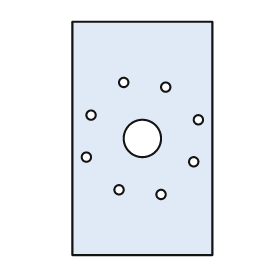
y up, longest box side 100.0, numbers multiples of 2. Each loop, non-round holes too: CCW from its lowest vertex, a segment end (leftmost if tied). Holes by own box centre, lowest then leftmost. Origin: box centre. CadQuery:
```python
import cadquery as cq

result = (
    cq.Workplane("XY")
    .moveTo(-30.0, -50.0)
    .lineTo(30.0, -50.0)
    .lineTo(30.0, 50.0)
    .lineTo(-30.0, 50.0)
    .close()
    .moveTo(8.0, -24.0)
    .circle(2.0)
    .moveTo(-10.0, -22.0)
    .circle(2.0)
    .moveTo(22.0, -10.0)
    .circle(2.0)
    .moveTo(-24.0, -8.0)
    .circle(2.0)
    .moveTo(0.0, 0.0)
    .circle(8.0)
    .moveTo(24.0, 8.0)
    .circle(2.0)
    .moveTo(-22.0, 10.0)
    .circle(2.0)
    .moveTo(10.0, 22.0)
    .circle(2.0)
    .moveTo(-8.0, 24.0)
    .circle(2.0)
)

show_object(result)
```